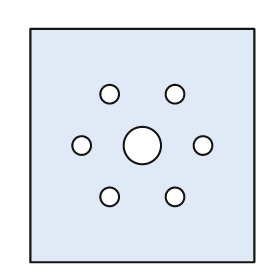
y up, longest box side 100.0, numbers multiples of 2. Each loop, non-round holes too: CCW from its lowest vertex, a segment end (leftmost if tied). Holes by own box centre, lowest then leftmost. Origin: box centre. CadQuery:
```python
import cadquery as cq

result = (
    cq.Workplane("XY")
    .moveTo(-48.0, -50.0)
    .lineTo(48.0, -50.0)
    .lineTo(48.0, 50.0)
    .lineTo(-48.0, 50.0)
    .close()
    .moveTo(-14.0, -22.0)
    .circle(4.0)
    .moveTo(14.0, -22.0)
    .circle(4.0)
    .moveTo(-26.0, 0.0)
    .circle(4.0)
    .moveTo(0.0, 0.0)
    .circle(8.0)
    .moveTo(26.0, 0.0)
    .circle(4.0)
    .moveTo(-14.0, 22.0)
    .circle(4.0)
    .moveTo(14.0, 22.0)
    .circle(4.0)
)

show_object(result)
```